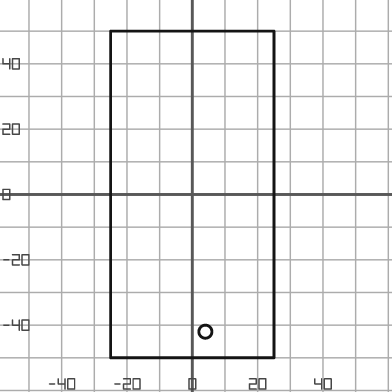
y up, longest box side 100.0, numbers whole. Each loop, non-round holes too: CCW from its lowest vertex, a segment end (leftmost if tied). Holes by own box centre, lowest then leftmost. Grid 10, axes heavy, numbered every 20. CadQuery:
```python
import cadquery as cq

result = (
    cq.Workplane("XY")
    .moveTo(-25.0, -50.0)
    .lineTo(25.0, -50.0)
    .lineTo(25.0, 50.0)
    .lineTo(-25.0, 50.0)
    .close()
    .moveTo(4.0, -42.0)
    .circle(2.0)
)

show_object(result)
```